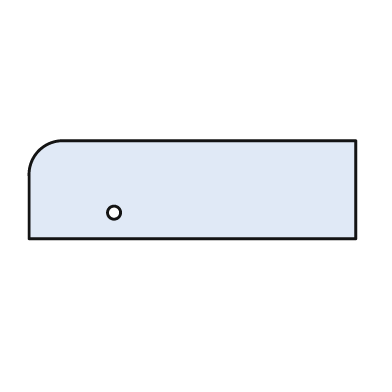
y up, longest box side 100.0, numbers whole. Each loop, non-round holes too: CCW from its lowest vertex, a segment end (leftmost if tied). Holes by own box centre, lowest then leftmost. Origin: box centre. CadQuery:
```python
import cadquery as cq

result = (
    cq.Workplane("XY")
    .moveTo(-50.0, -15.0)
    .lineTo(50.0, -15.0)
    .lineTo(50.0, 15.0)
    .lineTo(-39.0, 15.0)
    .threePointArc((-47.0, 12.0), (-50.0, 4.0))
    .close()
    .moveTo(-24.0, -7.0)
    .circle(2.0)
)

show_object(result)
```